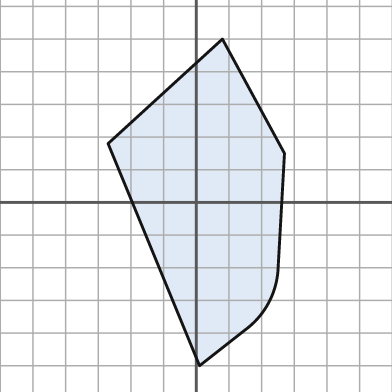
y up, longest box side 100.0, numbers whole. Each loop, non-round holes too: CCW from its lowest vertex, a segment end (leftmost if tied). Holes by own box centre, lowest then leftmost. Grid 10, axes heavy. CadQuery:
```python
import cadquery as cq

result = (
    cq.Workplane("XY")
    .moveTo(1.0, -50.0)
    .lineTo(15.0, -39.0)
    .threePointArc((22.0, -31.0), (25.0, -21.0))
    .lineTo(27.0, 15.0)
    .lineTo(8.0, 50.0)
    .lineTo(-27.0, 18.0)
    .close()
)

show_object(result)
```